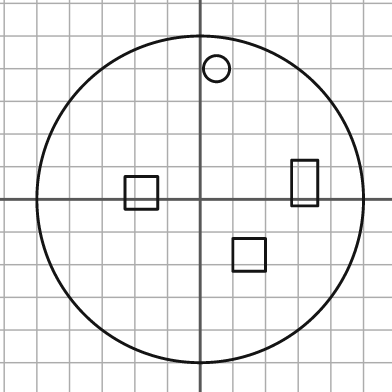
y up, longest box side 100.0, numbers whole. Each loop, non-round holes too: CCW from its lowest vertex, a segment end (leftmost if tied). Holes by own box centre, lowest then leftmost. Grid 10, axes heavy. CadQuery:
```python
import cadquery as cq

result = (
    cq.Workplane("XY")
    .moveTo(0.0, 0.0)
    .circle(50.0)
    .moveTo(10.0, -22.0)
    .lineTo(20.0, -22.0)
    .lineTo(20.0, -12.0)
    .lineTo(10.0, -12.0)
    .close()
    .moveTo(-23.0, -3.0)
    .lineTo(-13.0, -3.0)
    .lineTo(-13.0, 7.0)
    .lineTo(-23.0, 7.0)
    .close()
    .moveTo(28.0, -2.0)
    .lineTo(36.0, -2.0)
    .lineTo(36.0, 12.0)
    .lineTo(28.0, 12.0)
    .close()
    .moveTo(5.0, 40.0)
    .circle(4.0)
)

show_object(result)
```